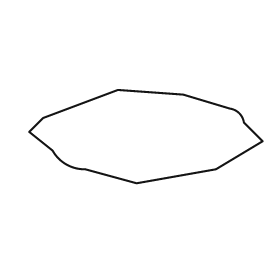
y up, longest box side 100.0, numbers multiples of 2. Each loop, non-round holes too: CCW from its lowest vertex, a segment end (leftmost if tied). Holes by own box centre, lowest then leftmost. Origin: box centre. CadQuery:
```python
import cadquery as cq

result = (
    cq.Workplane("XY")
    .moveTo(-4.0, -20.0)
    .lineTo(30.0, -14.0)
    .lineTo(50.0, -2.0)
    .lineTo(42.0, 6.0)
    .threePointArc((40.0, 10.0), (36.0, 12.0))
    .lineTo(16.0, 18.0)
    .lineTo(-12.0, 20.0)
    .lineTo(-44.0, 8.0)
    .lineTo(-50.0, 2.0)
    .lineTo(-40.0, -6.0)
    .threePointArc((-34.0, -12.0), (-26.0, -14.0))
    .close()
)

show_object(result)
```